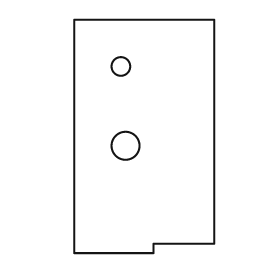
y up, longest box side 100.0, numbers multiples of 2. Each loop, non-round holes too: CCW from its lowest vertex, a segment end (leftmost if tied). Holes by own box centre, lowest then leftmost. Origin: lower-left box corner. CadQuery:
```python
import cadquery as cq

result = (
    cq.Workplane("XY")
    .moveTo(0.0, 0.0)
    .lineTo(34.0, 0.0)
    .lineTo(34.0, 4.0)
    .lineTo(60.0, 4.0)
    .lineTo(60.0, 100.0)
    .lineTo(0.0, 100.0)
    .close()
    .moveTo(22.0, 46.0)
    .circle(6.0)
    .moveTo(20.0, 80.0)
    .circle(4.0)
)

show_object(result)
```